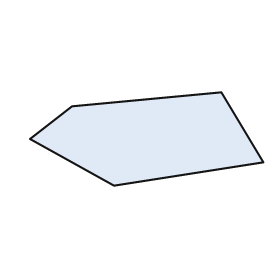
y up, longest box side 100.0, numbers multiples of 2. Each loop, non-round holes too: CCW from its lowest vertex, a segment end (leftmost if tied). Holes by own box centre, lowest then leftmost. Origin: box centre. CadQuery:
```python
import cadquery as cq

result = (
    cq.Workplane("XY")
    .moveTo(-14.0, -20.0)
    .lineTo(50.0, -10.0)
    .lineTo(32.0, 20.0)
    .lineTo(-32.0, 14.0)
    .lineTo(-50.0, 0.0)
    .close()
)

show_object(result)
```